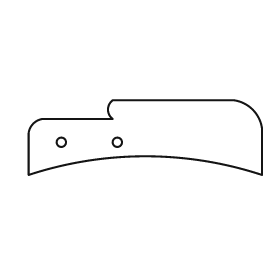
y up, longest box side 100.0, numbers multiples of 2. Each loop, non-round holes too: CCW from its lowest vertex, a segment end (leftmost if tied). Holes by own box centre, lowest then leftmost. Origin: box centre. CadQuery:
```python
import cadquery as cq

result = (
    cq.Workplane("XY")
    .moveTo(-50.0, -16.0)
    .threePointArc((0.0, -8.0), (50.0, -16.0))
    .lineTo(50.0, 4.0)
    .threePointArc((46.0, 12.0), (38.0, 16.0))
    .lineTo(-14.0, 16.0)
    .threePointArc((-16.0, 12.0), (-14.0, 8.0))
    .lineTo(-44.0, 8.0)
    .threePointArc((-48.0, 6.0), (-50.0, 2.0))
    .close()
    .moveTo(-36.0, -2.0)
    .circle(2.0)
    .moveTo(-12.0, -2.0)
    .circle(2.0)
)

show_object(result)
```